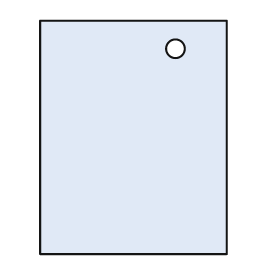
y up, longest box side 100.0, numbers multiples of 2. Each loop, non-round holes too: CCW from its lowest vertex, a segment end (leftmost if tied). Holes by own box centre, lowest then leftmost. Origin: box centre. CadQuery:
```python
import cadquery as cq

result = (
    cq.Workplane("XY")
    .moveTo(-40.0, -50.0)
    .lineTo(40.0, -50.0)
    .lineTo(40.0, 50.0)
    .lineTo(-40.0, 50.0)
    .close()
    .moveTo(18.0, 38.0)
    .circle(4.0)
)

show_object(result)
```